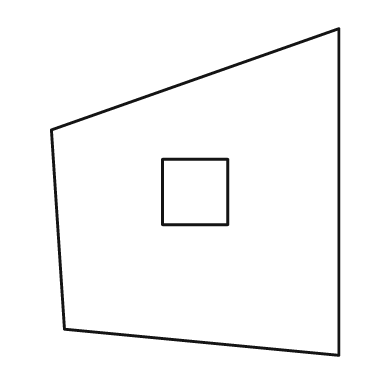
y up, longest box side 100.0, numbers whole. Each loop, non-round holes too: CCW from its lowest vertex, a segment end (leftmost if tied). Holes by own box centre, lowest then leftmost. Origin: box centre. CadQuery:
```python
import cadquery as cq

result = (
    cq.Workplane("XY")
    .moveTo(44.0, -50.0)
    .lineTo(44.0, 50.0)
    .lineTo(-44.0, 19.0)
    .lineTo(-40.0, -42.0)
    .close()
    .moveTo(-10.0, -10.0)
    .lineTo(10.0, -10.0)
    .lineTo(10.0, 10.0)
    .lineTo(-10.0, 10.0)
    .close()
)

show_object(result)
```